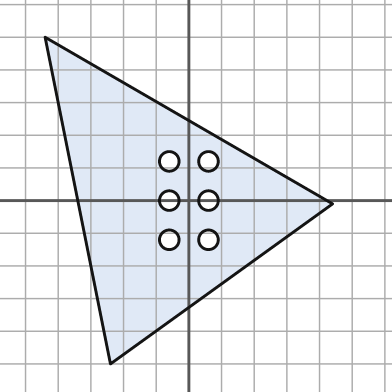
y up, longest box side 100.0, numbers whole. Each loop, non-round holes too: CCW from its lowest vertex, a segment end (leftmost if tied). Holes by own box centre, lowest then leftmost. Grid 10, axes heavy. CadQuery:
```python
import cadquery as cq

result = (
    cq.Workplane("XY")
    .moveTo(-24.0, -50.0)
    .lineTo(44.0, -1.0)
    .lineTo(-44.0, 50.0)
    .close()
    .moveTo(-6.0, -12.0)
    .circle(3.0)
    .moveTo(6.0, -12.0)
    .circle(3.0)
    .moveTo(-6.0, 0.0)
    .circle(3.0)
    .moveTo(6.0, 0.0)
    .circle(3.0)
    .moveTo(-6.0, 12.0)
    .circle(3.0)
    .moveTo(6.0, 12.0)
    .circle(3.0)
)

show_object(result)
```